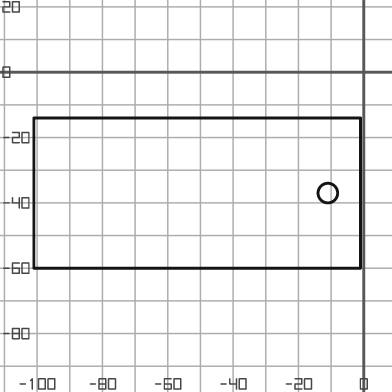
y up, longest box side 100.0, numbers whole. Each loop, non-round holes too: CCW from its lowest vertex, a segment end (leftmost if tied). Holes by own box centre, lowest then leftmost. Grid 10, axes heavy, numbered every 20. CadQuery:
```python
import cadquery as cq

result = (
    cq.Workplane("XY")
    .moveTo(-101.0, -60.0)
    .lineTo(-1.0, -60.0)
    .lineTo(-1.0, -14.0)
    .lineTo(-101.0, -14.0)
    .close()
    .moveTo(-11.0, -37.0)
    .circle(3.0)
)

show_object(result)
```